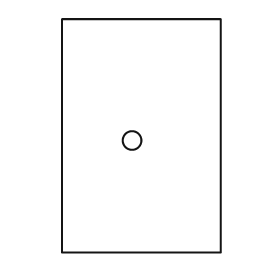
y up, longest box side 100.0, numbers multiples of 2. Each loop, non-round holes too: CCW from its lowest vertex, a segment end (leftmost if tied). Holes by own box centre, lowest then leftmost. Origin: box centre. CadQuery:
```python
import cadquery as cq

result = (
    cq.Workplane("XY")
    .moveTo(-34.0, -50.0)
    .lineTo(34.0, -50.0)
    .lineTo(34.0, 50.0)
    .lineTo(-34.0, 50.0)
    .close()
    .moveTo(-4.0, -2.0)
    .circle(4.0)
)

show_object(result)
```